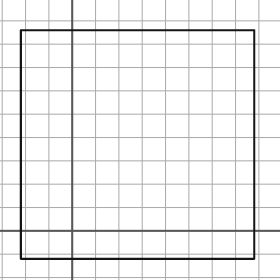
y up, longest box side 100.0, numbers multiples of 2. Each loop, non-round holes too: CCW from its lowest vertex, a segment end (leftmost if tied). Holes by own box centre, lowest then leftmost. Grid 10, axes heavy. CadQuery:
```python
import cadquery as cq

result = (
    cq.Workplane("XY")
    .moveTo(-22.0, -12.0)
    .lineTo(78.0, -12.0)
    .lineTo(78.0, 86.0)
    .lineTo(-22.0, 86.0)
    .close()
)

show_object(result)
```